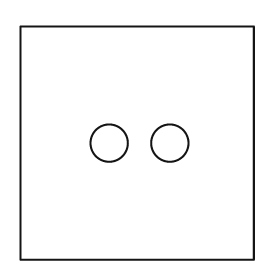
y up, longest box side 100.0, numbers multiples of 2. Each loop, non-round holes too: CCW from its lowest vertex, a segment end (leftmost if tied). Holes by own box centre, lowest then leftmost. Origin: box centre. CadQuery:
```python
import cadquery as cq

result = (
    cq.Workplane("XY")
    .moveTo(-50.0, -50.0)
    .lineTo(50.0, -50.0)
    .lineTo(50.0, 50.0)
    .lineTo(-50.0, 50.0)
    .close()
    .moveTo(-12.0, 0.0)
    .circle(8.0)
    .moveTo(14.0, 0.0)
    .circle(8.0)
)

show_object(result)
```